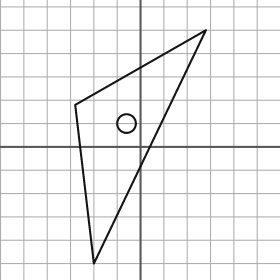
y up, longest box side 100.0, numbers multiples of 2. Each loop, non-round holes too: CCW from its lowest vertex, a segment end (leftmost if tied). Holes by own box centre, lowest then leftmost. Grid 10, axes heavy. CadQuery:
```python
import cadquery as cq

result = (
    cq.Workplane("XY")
    .moveTo(-20.0, -50.0)
    .lineTo(28.0, 50.0)
    .lineTo(-28.0, 18.0)
    .close()
    .moveTo(-6.0, 10.0)
    .circle(4.0)
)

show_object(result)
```